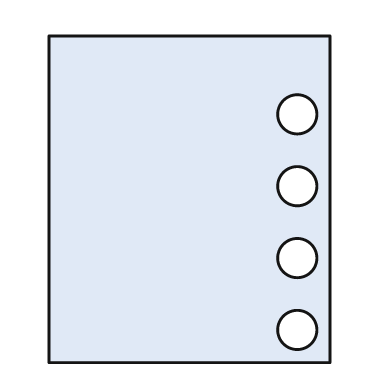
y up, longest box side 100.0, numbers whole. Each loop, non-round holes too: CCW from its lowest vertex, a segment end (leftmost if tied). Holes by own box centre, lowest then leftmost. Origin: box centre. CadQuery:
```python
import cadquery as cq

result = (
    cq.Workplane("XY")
    .moveTo(-43.0, -50.0)
    .lineTo(43.0, -50.0)
    .lineTo(43.0, 50.0)
    .lineTo(-43.0, 50.0)
    .close()
    .moveTo(33.0, -40.0)
    .circle(6.0)
    .moveTo(33.0, -18.0)
    .circle(6.0)
    .moveTo(33.0, 4.0)
    .circle(6.0)
    .moveTo(33.0, 26.0)
    .circle(6.0)
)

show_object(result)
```